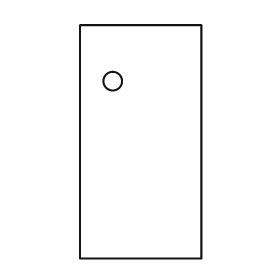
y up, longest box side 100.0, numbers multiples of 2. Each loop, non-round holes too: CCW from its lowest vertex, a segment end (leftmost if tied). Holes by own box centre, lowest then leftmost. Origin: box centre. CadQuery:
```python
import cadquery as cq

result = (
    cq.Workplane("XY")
    .moveTo(-26.0, -50.0)
    .lineTo(26.0, -50.0)
    .lineTo(26.0, 50.0)
    .lineTo(-26.0, 50.0)
    .close()
    .moveTo(-12.0, 26.0)
    .circle(4.0)
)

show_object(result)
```